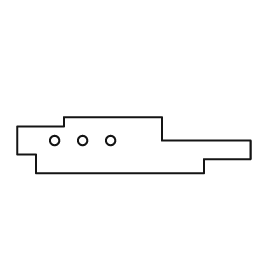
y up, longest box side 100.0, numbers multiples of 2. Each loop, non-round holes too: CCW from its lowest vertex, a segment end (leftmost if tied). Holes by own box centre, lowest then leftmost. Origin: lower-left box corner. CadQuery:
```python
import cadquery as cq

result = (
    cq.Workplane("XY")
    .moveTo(8.0, 0.0)
    .lineTo(80.0, 0.0)
    .lineTo(80.0, 6.0)
    .lineTo(100.0, 6.0)
    .lineTo(100.0, 14.0)
    .lineTo(62.0, 14.0)
    .lineTo(62.0, 24.0)
    .lineTo(20.0, 24.0)
    .lineTo(20.0, 20.0)
    .lineTo(0.0, 20.0)
    .lineTo(0.0, 8.0)
    .lineTo(8.0, 8.0)
    .close()
    .moveTo(16.0, 14.0)
    .circle(2.0)
    .moveTo(28.0, 14.0)
    .circle(2.0)
    .moveTo(40.0, 14.0)
    .circle(2.0)
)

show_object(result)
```